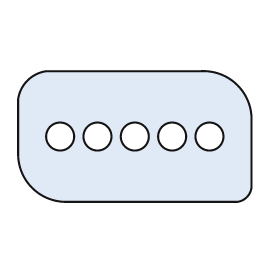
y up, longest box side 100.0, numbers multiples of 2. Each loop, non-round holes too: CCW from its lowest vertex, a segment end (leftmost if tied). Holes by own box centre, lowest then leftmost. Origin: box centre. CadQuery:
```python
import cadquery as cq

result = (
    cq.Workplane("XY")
    .moveTo(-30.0, -28.0)
    .lineTo(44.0, -28.0)
    .threePointArc((48.0, -26.0), (50.0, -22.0))
    .lineTo(50.0, 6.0)
    .threePointArc((44.0, 22.0), (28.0, 28.0))
    .lineTo(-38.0, 28.0)
    .threePointArc((-46.0, 24.0), (-50.0, 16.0))
    .lineTo(-50.0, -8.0)
    .threePointArc((-44.0, -22.0), (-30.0, -28.0))
    .close()
    .moveTo(-32.0, 0.0)
    .circle(6.0)
    .moveTo(-16.0, 0.0)
    .circle(6.0)
    .moveTo(0.0, 0.0)
    .circle(6.0)
    .moveTo(16.0, 0.0)
    .circle(6.0)
    .moveTo(32.0, 0.0)
    .circle(6.0)
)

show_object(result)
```